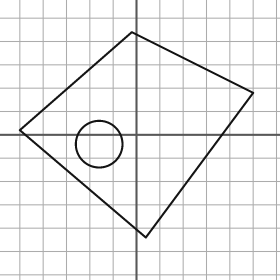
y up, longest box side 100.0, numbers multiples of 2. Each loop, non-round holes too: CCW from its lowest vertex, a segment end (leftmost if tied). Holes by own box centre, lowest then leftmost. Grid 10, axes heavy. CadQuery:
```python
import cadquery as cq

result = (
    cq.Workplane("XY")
    .moveTo(4.0, -44.0)
    .lineTo(50.0, 18.0)
    .lineTo(-2.0, 44.0)
    .lineTo(-50.0, 2.0)
    .close()
    .moveTo(-16.0, -4.0)
    .circle(10.0)
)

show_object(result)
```